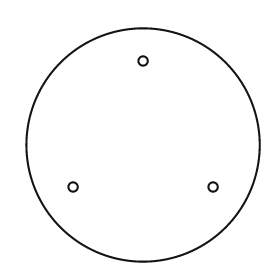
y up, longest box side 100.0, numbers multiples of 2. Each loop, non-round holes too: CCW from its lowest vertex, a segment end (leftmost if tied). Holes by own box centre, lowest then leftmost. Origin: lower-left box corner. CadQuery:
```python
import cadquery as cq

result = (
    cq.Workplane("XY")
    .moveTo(50.0, 50.0)
    .circle(50.0)
    .moveTo(20.0, 32.0)
    .circle(2.0)
    .moveTo(80.0, 32.0)
    .circle(2.0)
    .moveTo(50.0, 86.0)
    .circle(2.0)
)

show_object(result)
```